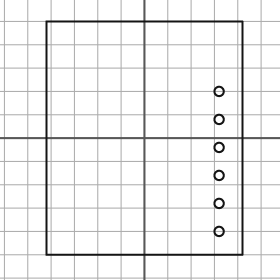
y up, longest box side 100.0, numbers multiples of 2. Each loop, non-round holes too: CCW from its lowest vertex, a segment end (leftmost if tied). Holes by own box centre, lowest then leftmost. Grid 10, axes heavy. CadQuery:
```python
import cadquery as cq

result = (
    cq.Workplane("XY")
    .moveTo(-42.0, -50.0)
    .lineTo(42.0, -50.0)
    .lineTo(42.0, 50.0)
    .lineTo(-42.0, 50.0)
    .close()
    .moveTo(32.0, -40.0)
    .circle(2.0)
    .moveTo(32.0, -28.0)
    .circle(2.0)
    .moveTo(32.0, -16.0)
    .circle(2.0)
    .moveTo(32.0, -4.0)
    .circle(2.0)
    .moveTo(32.0, 8.0)
    .circle(2.0)
    .moveTo(32.0, 20.0)
    .circle(2.0)
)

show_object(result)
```